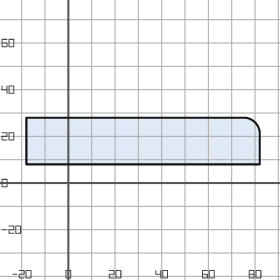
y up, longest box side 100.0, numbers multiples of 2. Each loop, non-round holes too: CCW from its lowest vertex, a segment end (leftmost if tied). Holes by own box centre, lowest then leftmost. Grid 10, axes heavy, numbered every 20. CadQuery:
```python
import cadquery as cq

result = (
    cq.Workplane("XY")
    .moveTo(-18.0, 8.0)
    .lineTo(82.0, 8.0)
    .lineTo(82.0, 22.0)
    .threePointArc((80.0, 26.0), (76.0, 28.0))
    .lineTo(-18.0, 28.0)
    .close()
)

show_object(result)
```